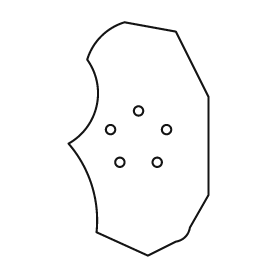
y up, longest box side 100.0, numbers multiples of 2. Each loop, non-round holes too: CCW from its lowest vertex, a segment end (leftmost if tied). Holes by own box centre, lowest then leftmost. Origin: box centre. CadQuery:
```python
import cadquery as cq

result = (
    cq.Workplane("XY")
    .moveTo(4.0, -50.0)
    .lineTo(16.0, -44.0)
    .threePointArc((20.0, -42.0), (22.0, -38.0))
    .lineTo(30.0, -24.0)
    .lineTo(30.0, 18.0)
    .lineTo(16.0, 46.0)
    .lineTo(-6.0, 50.0)
    .threePointArc((-16.0, 44.0), (-22.0, 34.0))
    .threePointArc((-18.0, 14.0), (-30.0, -2.0))
    .threePointArc((-20.0, -20.0), (-18.0, -40.0))
    .close()
    .moveTo(-8.0, -10.0)
    .circle(2.0)
    .moveTo(8.0, -10.0)
    .circle(2.0)
    .moveTo(-12.0, 4.0)
    .circle(2.0)
    .moveTo(12.0, 4.0)
    .circle(2.0)
    .moveTo(0.0, 12.0)
    .circle(2.0)
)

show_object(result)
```